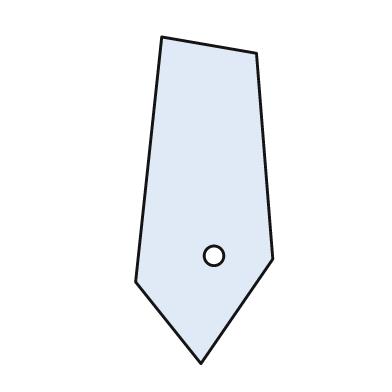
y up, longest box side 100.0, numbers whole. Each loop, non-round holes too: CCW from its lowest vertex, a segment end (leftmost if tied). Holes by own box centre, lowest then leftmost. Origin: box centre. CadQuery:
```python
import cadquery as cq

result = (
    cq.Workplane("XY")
    .moveTo(-1.0, -50.0)
    .lineTo(21.0, -18.0)
    .lineTo(16.0, 45.0)
    .lineTo(-13.0, 50.0)
    .lineTo(-21.0, -25.0)
    .close()
    .moveTo(3.0, -17.0)
    .circle(3.0)
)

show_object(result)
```